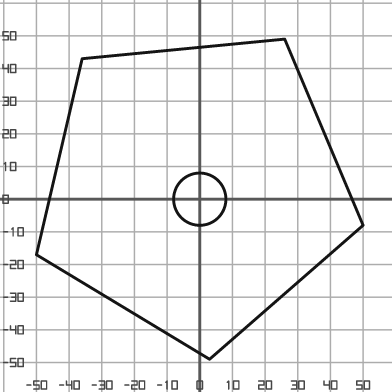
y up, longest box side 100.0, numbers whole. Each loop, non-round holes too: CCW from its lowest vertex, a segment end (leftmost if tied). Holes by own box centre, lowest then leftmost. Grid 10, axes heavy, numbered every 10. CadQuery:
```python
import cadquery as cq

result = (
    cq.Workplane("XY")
    .moveTo(3.0, -49.0)
    .lineTo(50.0, -8.0)
    .lineTo(26.0, 49.0)
    .lineTo(-36.0, 43.0)
    .lineTo(-50.0, -17.0)
    .close()
    .moveTo(0.0, 0.0)
    .circle(8.0)
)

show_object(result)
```